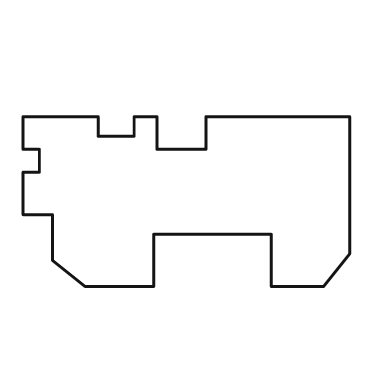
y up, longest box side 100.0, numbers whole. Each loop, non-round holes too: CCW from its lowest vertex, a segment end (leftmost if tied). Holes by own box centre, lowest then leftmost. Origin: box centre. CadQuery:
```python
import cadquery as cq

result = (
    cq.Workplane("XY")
    .moveTo(-31.0, -26.0)
    .lineTo(-10.0, -26.0)
    .lineTo(-10.0, -10.0)
    .lineTo(26.0, -10.0)
    .lineTo(26.0, -26.0)
    .lineTo(42.0, -26.0)
    .lineTo(50.0, -16.0)
    .lineTo(50.0, 26.0)
    .lineTo(6.0, 26.0)
    .lineTo(6.0, 16.0)
    .lineTo(-9.0, 16.0)
    .lineTo(-9.0, 26.0)
    .lineTo(-16.0, 26.0)
    .lineTo(-16.0, 20.0)
    .lineTo(-27.0, 20.0)
    .lineTo(-27.0, 26.0)
    .lineTo(-50.0, 26.0)
    .lineTo(-50.0, 16.0)
    .lineTo(-45.0, 16.0)
    .lineTo(-45.0, 9.0)
    .lineTo(-50.0, 9.0)
    .lineTo(-50.0, -4.0)
    .lineTo(-41.0, -4.0)
    .lineTo(-41.0, -18.0)
    .close()
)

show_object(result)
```